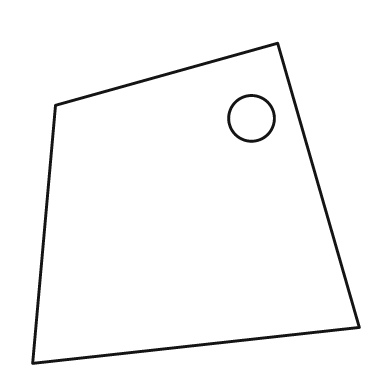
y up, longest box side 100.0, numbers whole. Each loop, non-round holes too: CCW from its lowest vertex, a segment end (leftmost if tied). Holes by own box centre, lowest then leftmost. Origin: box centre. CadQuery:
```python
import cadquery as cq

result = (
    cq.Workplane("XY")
    .moveTo(-50.0, -49.0)
    .lineTo(50.0, -38.0)
    .lineTo(25.0, 49.0)
    .lineTo(-43.0, 30.0)
    .close()
    .moveTo(17.0, 26.0)
    .circle(7.0)
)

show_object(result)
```